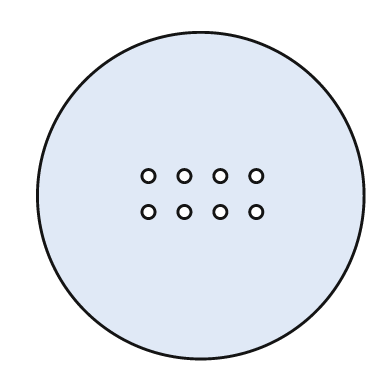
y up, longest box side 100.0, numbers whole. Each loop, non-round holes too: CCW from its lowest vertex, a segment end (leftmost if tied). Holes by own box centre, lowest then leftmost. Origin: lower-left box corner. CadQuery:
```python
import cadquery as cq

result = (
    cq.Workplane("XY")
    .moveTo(50.0, 50.0)
    .circle(50.0)
    .moveTo(34.0, 45.0)
    .circle(2.0)
    .moveTo(45.0, 45.0)
    .circle(2.0)
    .moveTo(56.0, 45.0)
    .circle(2.0)
    .moveTo(67.0, 45.0)
    .circle(2.0)
    .moveTo(34.0, 56.0)
    .circle(2.0)
    .moveTo(45.0, 56.0)
    .circle(2.0)
    .moveTo(56.0, 56.0)
    .circle(2.0)
    .moveTo(67.0, 56.0)
    .circle(2.0)
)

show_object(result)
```